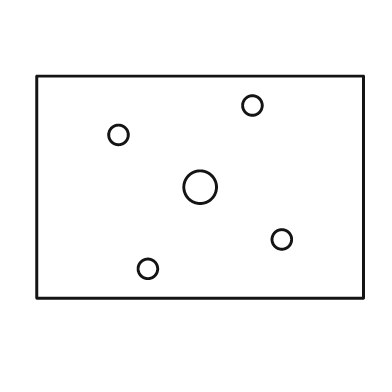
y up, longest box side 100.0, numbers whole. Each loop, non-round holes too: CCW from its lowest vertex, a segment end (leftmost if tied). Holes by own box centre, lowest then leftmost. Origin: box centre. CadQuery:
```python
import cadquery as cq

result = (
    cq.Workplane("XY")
    .moveTo(-50.0, -34.0)
    .lineTo(50.0, -34.0)
    .lineTo(50.0, 34.0)
    .lineTo(-50.0, 34.0)
    .close()
    .moveTo(-16.0, -25.0)
    .circle(3.0)
    .moveTo(25.0, -16.0)
    .circle(3.0)
    .moveTo(0.0, 0.0)
    .circle(5.0)
    .moveTo(-25.0, 16.0)
    .circle(3.0)
    .moveTo(16.0, 25.0)
    .circle(3.0)
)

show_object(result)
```